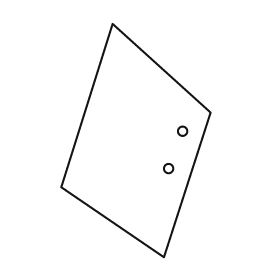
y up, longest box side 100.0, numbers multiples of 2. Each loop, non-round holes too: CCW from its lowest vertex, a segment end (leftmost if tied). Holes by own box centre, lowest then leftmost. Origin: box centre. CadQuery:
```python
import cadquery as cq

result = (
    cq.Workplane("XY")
    .moveTo(12.0, -50.0)
    .lineTo(32.0, 12.0)
    .lineTo(-10.0, 50.0)
    .lineTo(-32.0, -20.0)
    .close()
    .moveTo(14.0, -12.0)
    .circle(2.0)
    .moveTo(20.0, 4.0)
    .circle(2.0)
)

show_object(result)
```